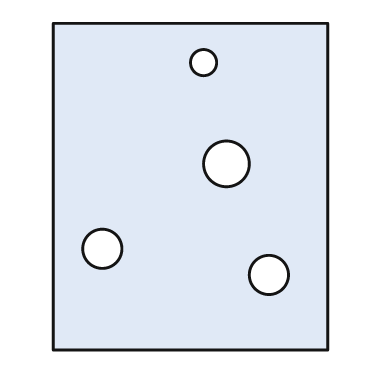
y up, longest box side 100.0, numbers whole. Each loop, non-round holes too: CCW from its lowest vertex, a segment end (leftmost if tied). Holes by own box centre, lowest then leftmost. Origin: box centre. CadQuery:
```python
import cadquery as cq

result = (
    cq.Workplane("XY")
    .moveTo(-42.0, -50.0)
    .lineTo(42.0, -50.0)
    .lineTo(42.0, 50.0)
    .lineTo(-42.0, 50.0)
    .close()
    .moveTo(24.0, -27.0)
    .circle(6.0)
    .moveTo(-27.0, -19.0)
    .circle(6.0)
    .moveTo(11.0, 7.0)
    .circle(7.0)
    .moveTo(4.0, 38.0)
    .circle(4.0)
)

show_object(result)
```